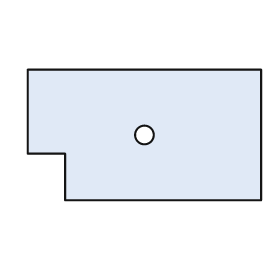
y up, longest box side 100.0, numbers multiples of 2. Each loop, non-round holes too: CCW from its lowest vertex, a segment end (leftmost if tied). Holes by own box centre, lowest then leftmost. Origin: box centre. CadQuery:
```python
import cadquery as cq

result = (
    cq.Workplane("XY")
    .moveTo(-34.0, -28.0)
    .lineTo(50.0, -28.0)
    .lineTo(50.0, 28.0)
    .lineTo(-50.0, 28.0)
    .lineTo(-50.0, -8.0)
    .lineTo(-34.0, -8.0)
    .close()
    .moveTo(0.0, 0.0)
    .circle(4.0)
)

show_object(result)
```